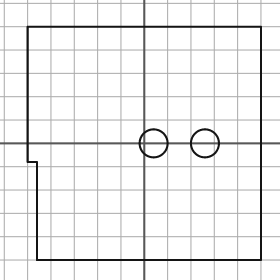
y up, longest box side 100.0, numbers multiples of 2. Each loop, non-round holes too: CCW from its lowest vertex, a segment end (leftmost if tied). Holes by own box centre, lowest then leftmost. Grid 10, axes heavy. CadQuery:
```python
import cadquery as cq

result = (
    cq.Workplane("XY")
    .moveTo(-46.0, -50.0)
    .lineTo(50.0, -50.0)
    .lineTo(50.0, 50.0)
    .lineTo(-50.0, 50.0)
    .lineTo(-50.0, -8.0)
    .lineTo(-46.0, -8.0)
    .close()
    .moveTo(4.0, 0.0)
    .circle(6.0)
    .moveTo(26.0, 0.0)
    .circle(6.0)
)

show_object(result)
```